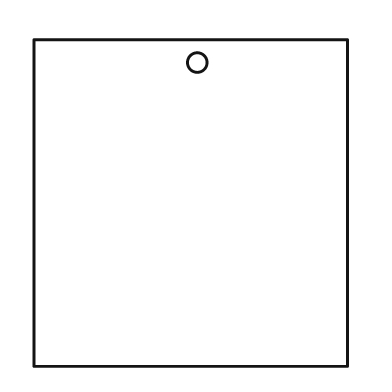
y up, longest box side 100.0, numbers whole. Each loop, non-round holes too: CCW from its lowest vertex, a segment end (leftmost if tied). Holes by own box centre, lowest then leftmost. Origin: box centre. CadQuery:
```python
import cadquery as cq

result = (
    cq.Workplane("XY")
    .moveTo(-48.0, -50.0)
    .lineTo(48.0, -50.0)
    .lineTo(48.0, 50.0)
    .lineTo(-48.0, 50.0)
    .close()
    .moveTo(2.0, 43.0)
    .circle(3.0)
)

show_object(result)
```